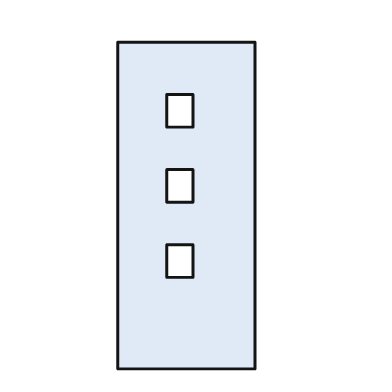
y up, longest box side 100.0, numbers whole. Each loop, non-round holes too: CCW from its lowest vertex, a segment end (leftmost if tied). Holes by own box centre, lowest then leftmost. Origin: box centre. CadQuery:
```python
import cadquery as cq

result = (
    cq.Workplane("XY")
    .moveTo(-21.0, -50.0)
    .lineTo(21.0, -50.0)
    .lineTo(21.0, 50.0)
    .lineTo(-21.0, 50.0)
    .close()
    .moveTo(-6.0, -22.0)
    .lineTo(2.0, -22.0)
    .lineTo(2.0, -12.0)
    .lineTo(-6.0, -12.0)
    .close()
    .moveTo(-6.0, 1.0)
    .lineTo(2.0, 1.0)
    .lineTo(2.0, 11.0)
    .lineTo(-6.0, 11.0)
    .close()
    .moveTo(-6.0, 24.0)
    .lineTo(2.0, 24.0)
    .lineTo(2.0, 34.0)
    .lineTo(-6.0, 34.0)
    .close()
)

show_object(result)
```